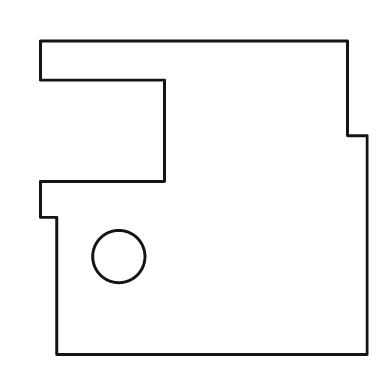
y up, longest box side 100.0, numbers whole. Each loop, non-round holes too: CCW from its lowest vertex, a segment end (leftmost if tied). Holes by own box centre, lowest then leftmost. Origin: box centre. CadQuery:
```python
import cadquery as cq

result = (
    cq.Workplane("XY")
    .moveTo(-45.0, -48.0)
    .lineTo(50.0, -48.0)
    .lineTo(50.0, 19.0)
    .lineTo(44.0, 19.0)
    .lineTo(44.0, 48.0)
    .lineTo(-50.0, 48.0)
    .lineTo(-50.0, 36.0)
    .lineTo(-12.0, 36.0)
    .lineTo(-12.0, 5.0)
    .lineTo(-50.0, 5.0)
    .lineTo(-50.0, -6.0)
    .lineTo(-45.0, -6.0)
    .close()
    .moveTo(-26.0, -18.0)
    .circle(8.0)
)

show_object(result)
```